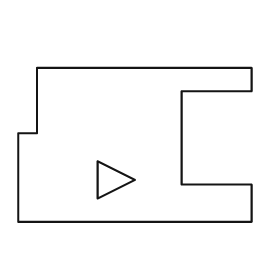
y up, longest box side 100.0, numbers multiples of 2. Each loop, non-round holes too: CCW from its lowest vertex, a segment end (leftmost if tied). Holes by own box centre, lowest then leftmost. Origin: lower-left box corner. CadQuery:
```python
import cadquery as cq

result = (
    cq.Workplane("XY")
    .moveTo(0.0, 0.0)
    .lineTo(100.0, 0.0)
    .lineTo(100.0, 16.0)
    .lineTo(70.0, 16.0)
    .lineTo(70.0, 56.0)
    .lineTo(100.0, 56.0)
    .lineTo(100.0, 66.0)
    .lineTo(8.0, 66.0)
    .lineTo(8.0, 38.0)
    .lineTo(0.0, 38.0)
    .close()
    .moveTo(34.0, 10.0)
    .lineTo(50.0, 18.0)
    .lineTo(34.0, 26.0)
    .close()
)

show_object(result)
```